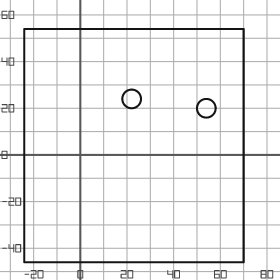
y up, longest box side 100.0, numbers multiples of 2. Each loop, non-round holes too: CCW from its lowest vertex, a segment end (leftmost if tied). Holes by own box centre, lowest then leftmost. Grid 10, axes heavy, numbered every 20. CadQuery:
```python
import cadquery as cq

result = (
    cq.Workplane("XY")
    .moveTo(-24.0, -46.0)
    .lineTo(70.0, -46.0)
    .lineTo(70.0, 54.0)
    .lineTo(-24.0, 54.0)
    .close()
    .moveTo(54.0, 20.0)
    .circle(4.0)
    .moveTo(22.0, 24.0)
    .circle(4.0)
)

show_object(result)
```